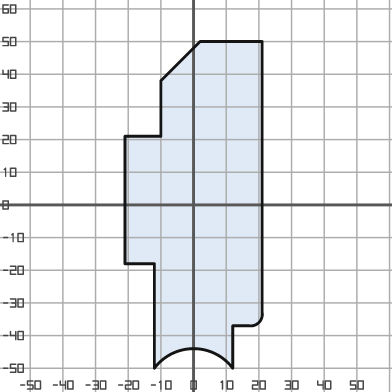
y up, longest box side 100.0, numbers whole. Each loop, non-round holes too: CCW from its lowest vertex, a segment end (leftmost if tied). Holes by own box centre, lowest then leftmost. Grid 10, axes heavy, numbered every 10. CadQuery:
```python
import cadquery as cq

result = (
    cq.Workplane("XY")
    .moveTo(-12.0, -50.0)
    .threePointArc((0.0, -44.0), (12.0, -50.0))
    .lineTo(12.0, -37.0)
    .lineTo(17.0, -37.0)
    .threePointArc((20.0, -36.0), (21.0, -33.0))
    .lineTo(21.0, 50.0)
    .lineTo(2.0, 50.0)
    .lineTo(-10.0, 38.0)
    .lineTo(-10.0, 21.0)
    .lineTo(-21.0, 21.0)
    .lineTo(-21.0, -18.0)
    .lineTo(-12.0, -18.0)
    .close()
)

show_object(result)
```